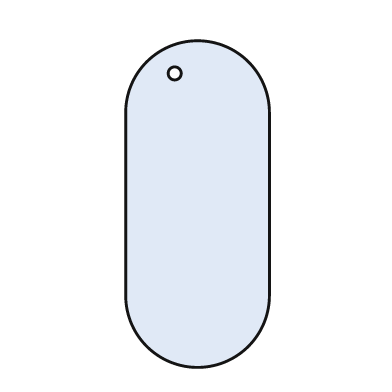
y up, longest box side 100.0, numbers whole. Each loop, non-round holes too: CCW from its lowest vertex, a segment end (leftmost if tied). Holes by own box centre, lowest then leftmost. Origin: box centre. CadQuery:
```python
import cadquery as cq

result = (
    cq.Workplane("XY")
    .moveTo(-22.0, -28.0)
    .threePointArc((0.0, -50.0), (22.0, -28.0))
    .lineTo(22.0, 28.0)
    .threePointArc((0.0, 50.0), (-22.0, 28.0))
    .close()
    .moveTo(-7.0, 40.0)
    .circle(2.0)
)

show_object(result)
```